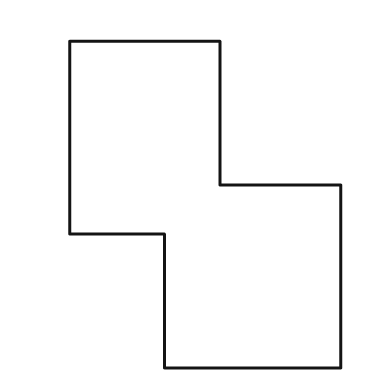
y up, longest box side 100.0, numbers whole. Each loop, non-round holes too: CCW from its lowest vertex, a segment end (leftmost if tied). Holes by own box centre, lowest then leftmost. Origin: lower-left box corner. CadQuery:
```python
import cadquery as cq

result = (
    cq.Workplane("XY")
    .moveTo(29.0, 0.0)
    .lineTo(83.0, 0.0)
    .lineTo(83.0, 56.0)
    .lineTo(46.0, 56.0)
    .lineTo(46.0, 100.0)
    .lineTo(0.0, 100.0)
    .lineTo(0.0, 41.0)
    .lineTo(29.0, 41.0)
    .close()
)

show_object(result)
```